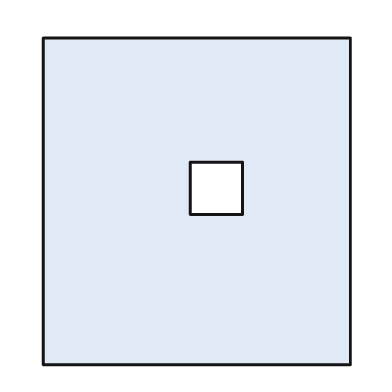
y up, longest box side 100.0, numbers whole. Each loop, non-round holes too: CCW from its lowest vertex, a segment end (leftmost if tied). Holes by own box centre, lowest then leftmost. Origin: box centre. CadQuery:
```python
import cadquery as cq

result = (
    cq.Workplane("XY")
    .moveTo(-47.0, -50.0)
    .lineTo(47.0, -50.0)
    .lineTo(47.0, 50.0)
    .lineTo(-47.0, 50.0)
    .close()
    .moveTo(-2.0, -4.0)
    .lineTo(14.0, -4.0)
    .lineTo(14.0, 12.0)
    .lineTo(-2.0, 12.0)
    .close()
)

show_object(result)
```